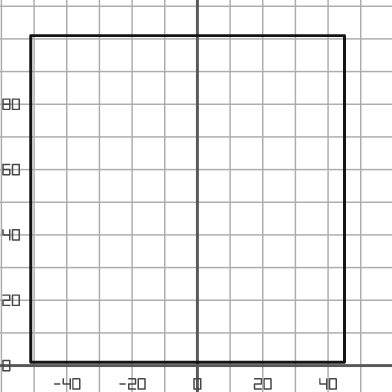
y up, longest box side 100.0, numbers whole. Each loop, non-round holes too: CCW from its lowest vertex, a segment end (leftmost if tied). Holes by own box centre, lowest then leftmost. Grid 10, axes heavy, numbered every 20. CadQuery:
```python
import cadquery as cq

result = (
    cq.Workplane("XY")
    .moveTo(-51.0, 1.0)
    .lineTo(45.0, 1.0)
    .lineTo(45.0, 101.0)
    .lineTo(-51.0, 101.0)
    .close()
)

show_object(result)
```